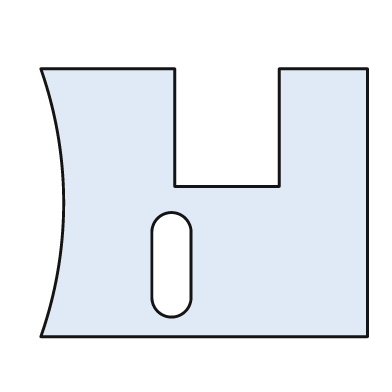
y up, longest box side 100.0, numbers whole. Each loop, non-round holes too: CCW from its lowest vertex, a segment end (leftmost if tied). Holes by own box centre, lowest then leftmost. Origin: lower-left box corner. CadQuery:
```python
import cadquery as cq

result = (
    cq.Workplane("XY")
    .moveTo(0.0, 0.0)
    .lineTo(100.0, 0.0)
    .lineTo(100.0, 82.0)
    .lineTo(73.0, 82.0)
    .lineTo(73.0, 46.0)
    .lineTo(41.0, 46.0)
    .lineTo(41.0, 82.0)
    .lineTo(0.0, 82.0)
    .threePointArc((7.0, 41.0), (0.0, 0.0))
    .close()
    .moveTo(34.0, 12.0)
    .threePointArc((40.0, 6.0), (46.0, 12.0))
    .lineTo(46.0, 32.0)
    .threePointArc((40.0, 38.0), (34.0, 32.0))
    .close()
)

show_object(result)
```